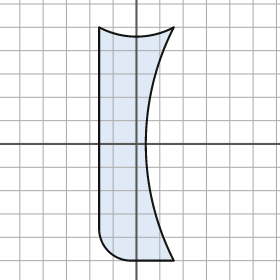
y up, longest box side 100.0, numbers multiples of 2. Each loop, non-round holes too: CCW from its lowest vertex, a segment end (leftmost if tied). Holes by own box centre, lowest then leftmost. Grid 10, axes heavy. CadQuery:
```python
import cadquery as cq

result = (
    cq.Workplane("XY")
    .moveTo(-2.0, -50.0)
    .lineTo(16.0, -50.0)
    .threePointArc((4.0, 0.0), (16.0, 50.0))
    .threePointArc((0.0, 46.0), (-16.0, 50.0))
    .lineTo(-16.0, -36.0)
    .threePointArc((-12.0, -46.0), (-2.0, -50.0))
    .close()
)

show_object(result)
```